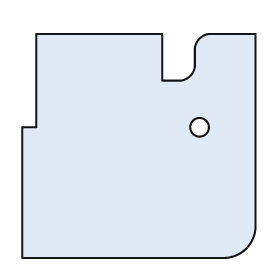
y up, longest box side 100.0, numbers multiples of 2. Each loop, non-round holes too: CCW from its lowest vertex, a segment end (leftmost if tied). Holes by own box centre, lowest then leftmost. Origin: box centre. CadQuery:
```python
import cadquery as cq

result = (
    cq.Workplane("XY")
    .moveTo(-50.0, -48.0)
    .lineTo(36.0, -48.0)
    .threePointArc((46.0, -44.0), (50.0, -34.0))
    .lineTo(50.0, 48.0)
    .lineTo(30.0, 48.0)
    .threePointArc((26.0, 46.0), (24.0, 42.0))
    .lineTo(24.0, 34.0)
    .threePointArc((22.0, 30.0), (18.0, 28.0))
    .lineTo(10.0, 28.0)
    .lineTo(10.0, 48.0)
    .lineTo(-44.0, 48.0)
    .lineTo(-44.0, 8.0)
    .lineTo(-50.0, 8.0)
    .close()
    .moveTo(26.0, 8.0)
    .circle(4.0)
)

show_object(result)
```